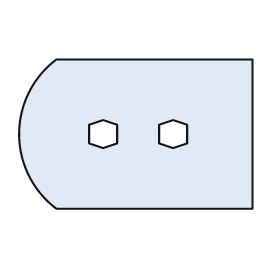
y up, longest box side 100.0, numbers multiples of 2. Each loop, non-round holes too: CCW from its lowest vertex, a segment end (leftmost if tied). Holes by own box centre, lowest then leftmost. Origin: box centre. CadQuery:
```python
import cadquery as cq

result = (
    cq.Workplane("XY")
    .moveTo(-34.0, -32.0)
    .lineTo(50.0, -32.0)
    .lineTo(50.0, 32.0)
    .lineTo(-34.0, 32.0)
    .threePointArc((-50.0, 0.0), (-34.0, -32.0))
    .close()
    .moveTo(-14.0, -6.0)
    .lineTo(-8.0, -4.0)
    .lineTo(-8.0, 4.0)
    .lineTo(-14.0, 6.0)
    .lineTo(-20.0, 4.0)
    .lineTo(-20.0, -4.0)
    .close()
    .moveTo(16.0, -6.0)
    .lineTo(22.0, -4.0)
    .lineTo(22.0, 4.0)
    .lineTo(16.0, 6.0)
    .lineTo(10.0, 4.0)
    .lineTo(10.0, -4.0)
    .close()
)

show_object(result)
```